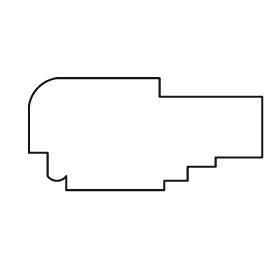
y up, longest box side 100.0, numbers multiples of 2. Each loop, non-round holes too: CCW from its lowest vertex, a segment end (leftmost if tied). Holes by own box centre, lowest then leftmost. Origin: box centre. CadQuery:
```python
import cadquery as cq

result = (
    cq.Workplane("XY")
    .moveTo(-34.0, -24.0)
    .lineTo(8.0, -24.0)
    .lineTo(8.0, -20.0)
    .lineTo(18.0, -20.0)
    .lineTo(18.0, -14.0)
    .lineTo(30.0, -14.0)
    .lineTo(30.0, -10.0)
    .lineTo(50.0, -10.0)
    .lineTo(50.0, 16.0)
    .lineTo(6.0, 16.0)
    .lineTo(6.0, 24.0)
    .lineTo(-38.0, 24.0)
    .threePointArc((-46.0, 20.0), (-50.0, 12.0))
    .lineTo(-50.0, -8.0)
    .lineTo(-42.0, -8.0)
    .lineTo(-42.0, -18.0)
    .threePointArc((-38.0, -20.0), (-34.0, -18.0))
    .close()
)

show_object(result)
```